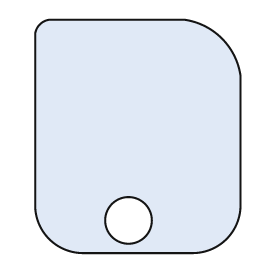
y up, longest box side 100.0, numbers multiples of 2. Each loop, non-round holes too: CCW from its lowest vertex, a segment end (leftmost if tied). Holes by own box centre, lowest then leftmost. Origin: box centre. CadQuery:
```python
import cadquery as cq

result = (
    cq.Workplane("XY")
    .moveTo(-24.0, -50.0)
    .lineTo(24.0, -50.0)
    .threePointArc((38.0, -44.0), (44.0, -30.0))
    .lineTo(44.0, 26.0)
    .threePointArc((36.0, 42.0), (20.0, 50.0))
    .lineTo(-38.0, 50.0)
    .threePointArc((-42.0, 48.0), (-44.0, 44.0))
    .lineTo(-44.0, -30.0)
    .threePointArc((-38.0, -44.0), (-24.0, -50.0))
    .close()
    .moveTo(-4.0, -36.0)
    .circle(10.0)
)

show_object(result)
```